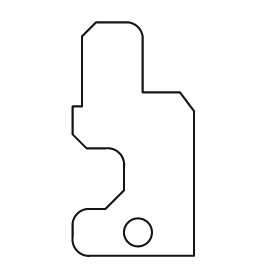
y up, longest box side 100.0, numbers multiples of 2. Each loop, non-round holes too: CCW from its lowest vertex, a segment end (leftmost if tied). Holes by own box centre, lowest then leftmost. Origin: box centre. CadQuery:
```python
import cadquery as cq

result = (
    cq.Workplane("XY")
    .moveTo(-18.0, -50.0)
    .lineTo(26.0, -50.0)
    .lineTo(26.0, 12.0)
    .lineTo(20.0, 20.0)
    .lineTo(4.0, 20.0)
    .lineTo(4.0, 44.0)
    .threePointArc((2.0, 48.0), (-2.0, 50.0))
    .lineTo(-16.0, 50.0)
    .lineTo(-22.0, 44.0)
    .lineTo(-22.0, 14.0)
    .lineTo(-26.0, 14.0)
    .lineTo(-26.0, 2.0)
    .lineTo(-20.0, -4.0)
    .lineTo(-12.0, -4.0)
    .threePointArc((-6.0, -6.0), (-4.0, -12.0))
    .lineTo(-4.0, -22.0)
    .lineTo(-12.0, -30.0)
    .lineTo(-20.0, -30.0)
    .threePointArc((-24.0, -32.0), (-26.0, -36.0))
    .lineTo(-26.0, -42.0)
    .threePointArc((-24.0, -48.0), (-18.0, -50.0))
    .close()
    .moveTo(2.0, -40.0)
    .circle(6.0)
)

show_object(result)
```